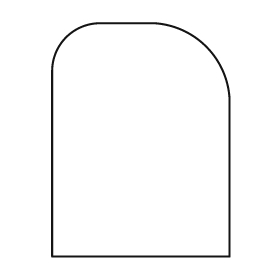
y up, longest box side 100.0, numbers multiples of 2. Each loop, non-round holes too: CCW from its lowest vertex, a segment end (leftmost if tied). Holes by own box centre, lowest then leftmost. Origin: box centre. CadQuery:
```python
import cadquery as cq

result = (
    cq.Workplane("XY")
    .moveTo(-38.0, -50.0)
    .lineTo(38.0, -50.0)
    .lineTo(38.0, 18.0)
    .threePointArc((28.0, 40.0), (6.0, 50.0))
    .lineTo(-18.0, 50.0)
    .threePointArc((-32.0, 44.0), (-38.0, 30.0))
    .close()
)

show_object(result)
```